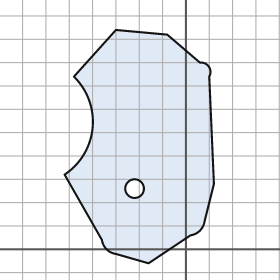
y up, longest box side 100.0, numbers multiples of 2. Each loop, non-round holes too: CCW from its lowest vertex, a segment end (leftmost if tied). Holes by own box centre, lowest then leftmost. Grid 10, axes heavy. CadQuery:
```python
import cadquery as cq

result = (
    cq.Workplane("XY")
    .moveTo(-16.0, -6.0)
    .lineTo(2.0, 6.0)
    .threePointArc((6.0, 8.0), (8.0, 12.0))
    .lineTo(12.0, 28.0)
    .lineTo(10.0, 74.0)
    .threePointArc((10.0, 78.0), (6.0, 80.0))
    .lineTo(-8.0, 92.0)
    .lineTo(-30.0, 94.0)
    .lineTo(-48.0, 74.0)
    .threePointArc((-40.0, 52.0), (-52.0, 32.0))
    .lineTo(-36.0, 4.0)
    .threePointArc((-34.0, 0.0), (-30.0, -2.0))
    .close()
    .moveTo(-22.0, 26.0)
    .circle(4.0)
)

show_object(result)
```